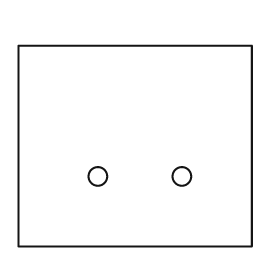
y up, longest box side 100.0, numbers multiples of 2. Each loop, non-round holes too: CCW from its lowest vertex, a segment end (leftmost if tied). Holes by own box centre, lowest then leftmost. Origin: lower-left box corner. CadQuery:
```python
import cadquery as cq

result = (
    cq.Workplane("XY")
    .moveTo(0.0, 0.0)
    .lineTo(100.0, 0.0)
    .lineTo(100.0, 86.0)
    .lineTo(0.0, 86.0)
    .close()
    .moveTo(34.0, 30.0)
    .circle(4.0)
    .moveTo(70.0, 30.0)
    .circle(4.0)
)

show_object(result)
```